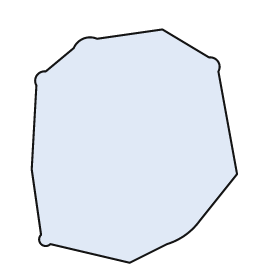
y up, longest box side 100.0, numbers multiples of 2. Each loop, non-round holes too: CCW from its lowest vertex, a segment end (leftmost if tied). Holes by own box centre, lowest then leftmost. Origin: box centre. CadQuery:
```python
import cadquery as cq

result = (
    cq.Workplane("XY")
    .moveTo(-2.0, -50.0)
    .lineTo(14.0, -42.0)
    .threePointArc((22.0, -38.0), (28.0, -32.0))
    .lineTo(44.0, -12.0)
    .lineTo(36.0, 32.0)
    .threePointArc((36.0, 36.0), (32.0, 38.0))
    .lineTo(12.0, 50.0)
    .lineTo(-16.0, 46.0)
    .threePointArc((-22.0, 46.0), (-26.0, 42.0))
    .lineTo(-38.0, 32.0)
    .threePointArc((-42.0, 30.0), (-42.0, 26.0))
    .lineTo(-44.0, -10.0)
    .lineTo(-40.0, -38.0)
    .threePointArc((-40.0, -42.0), (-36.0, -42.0))
    .close()
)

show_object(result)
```